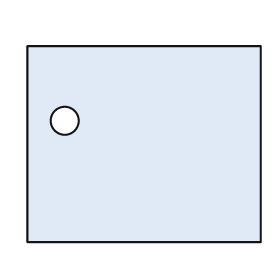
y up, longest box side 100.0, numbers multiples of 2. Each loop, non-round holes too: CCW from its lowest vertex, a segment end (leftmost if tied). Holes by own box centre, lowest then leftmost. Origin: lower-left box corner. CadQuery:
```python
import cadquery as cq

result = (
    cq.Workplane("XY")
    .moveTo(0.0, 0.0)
    .lineTo(100.0, 0.0)
    .lineTo(100.0, 84.0)
    .lineTo(0.0, 84.0)
    .close()
    .moveTo(16.0, 52.0)
    .circle(6.0)
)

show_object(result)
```